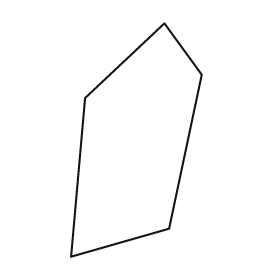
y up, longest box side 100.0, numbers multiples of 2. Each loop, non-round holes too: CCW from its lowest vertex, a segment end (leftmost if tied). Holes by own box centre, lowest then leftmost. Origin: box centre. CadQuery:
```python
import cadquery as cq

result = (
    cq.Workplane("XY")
    .moveTo(-28.0, -50.0)
    .lineTo(14.0, -38.0)
    .lineTo(28.0, 28.0)
    .lineTo(12.0, 50.0)
    .lineTo(-22.0, 18.0)
    .close()
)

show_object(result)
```